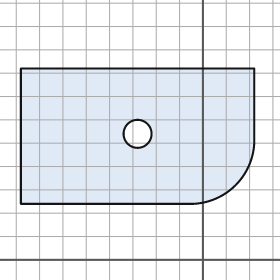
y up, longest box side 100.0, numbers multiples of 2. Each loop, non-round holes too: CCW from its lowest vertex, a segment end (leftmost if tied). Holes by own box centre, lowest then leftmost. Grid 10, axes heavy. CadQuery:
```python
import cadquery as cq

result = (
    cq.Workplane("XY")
    .moveTo(-78.0, 24.0)
    .lineTo(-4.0, 24.0)
    .threePointArc((14.0, 32.0), (22.0, 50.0))
    .lineTo(22.0, 82.0)
    .lineTo(-78.0, 82.0)
    .close()
    .moveTo(-28.0, 54.0)
    .circle(6.0)
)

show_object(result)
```